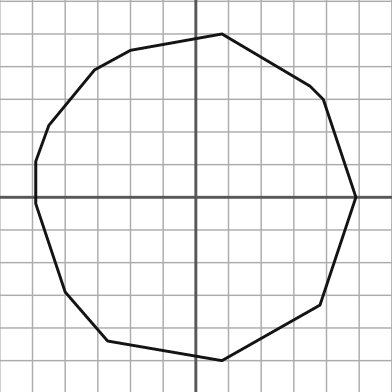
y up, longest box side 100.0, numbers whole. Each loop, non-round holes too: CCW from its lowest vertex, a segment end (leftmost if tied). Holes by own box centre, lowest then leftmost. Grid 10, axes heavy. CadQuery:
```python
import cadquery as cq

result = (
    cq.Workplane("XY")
    .moveTo(8.0, -50.0)
    .lineTo(38.0, -33.0)
    .lineTo(49.0, 0.0)
    .lineTo(39.0, 30.0)
    .lineTo(35.0, 34.0)
    .lineTo(8.0, 50.0)
    .lineTo(-20.0, 45.0)
    .lineTo(-31.0, 39.0)
    .lineTo(-45.0, 22.0)
    .lineTo(-49.0, 11.0)
    .lineTo(-49.0, -2.0)
    .lineTo(-40.0, -29.0)
    .lineTo(-27.0, -44.0)
    .close()
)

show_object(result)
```